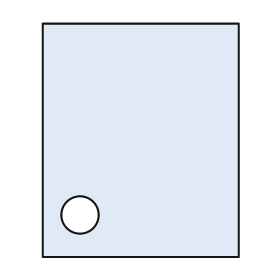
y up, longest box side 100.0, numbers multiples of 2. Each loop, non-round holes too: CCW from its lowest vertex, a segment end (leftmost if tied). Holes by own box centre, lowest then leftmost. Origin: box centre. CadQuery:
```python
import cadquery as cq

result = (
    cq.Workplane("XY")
    .moveTo(-42.0, -50.0)
    .lineTo(42.0, -50.0)
    .lineTo(42.0, 50.0)
    .lineTo(-42.0, 50.0)
    .close()
    .moveTo(-26.0, -32.0)
    .circle(8.0)
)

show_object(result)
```